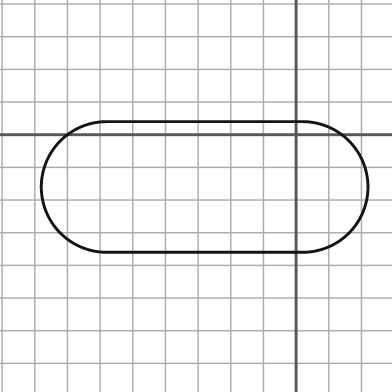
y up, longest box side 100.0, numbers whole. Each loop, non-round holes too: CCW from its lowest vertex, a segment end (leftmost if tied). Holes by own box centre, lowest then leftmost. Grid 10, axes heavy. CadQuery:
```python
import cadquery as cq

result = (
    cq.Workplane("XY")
    .moveTo(-58.0, -36.0)
    .lineTo(2.0, -36.0)
    .threePointArc((22.0, -16.0), (2.0, 4.0))
    .lineTo(-58.0, 4.0)
    .threePointArc((-78.0, -16.0), (-58.0, -36.0))
    .close()
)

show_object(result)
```